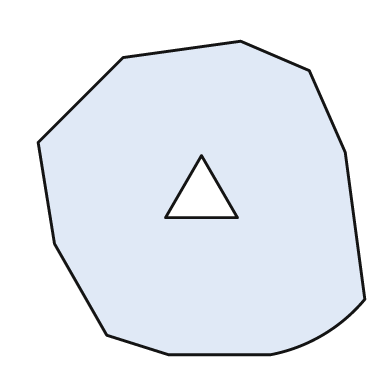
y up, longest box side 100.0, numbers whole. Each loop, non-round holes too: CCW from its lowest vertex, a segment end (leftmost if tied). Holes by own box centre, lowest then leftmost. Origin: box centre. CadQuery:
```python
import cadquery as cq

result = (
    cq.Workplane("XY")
    .moveTo(-10.0, -48.0)
    .lineTo(21.0, -48.0)
    .threePointArc((37.0, -42.0), (50.0, -31.0))
    .lineTo(44.0, 14.0)
    .lineTo(33.0, 39.0)
    .lineTo(12.0, 48.0)
    .lineTo(-24.0, 43.0)
    .lineTo(-50.0, 17.0)
    .lineTo(-45.0, -14.0)
    .lineTo(-29.0, -42.0)
    .close()
    .moveTo(-11.0, -6.0)
    .lineTo(11.0, -6.0)
    .lineTo(0.0, 13.0)
    .close()
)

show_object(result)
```